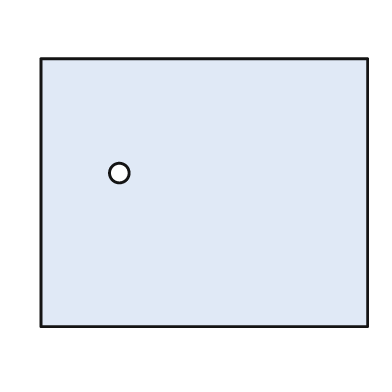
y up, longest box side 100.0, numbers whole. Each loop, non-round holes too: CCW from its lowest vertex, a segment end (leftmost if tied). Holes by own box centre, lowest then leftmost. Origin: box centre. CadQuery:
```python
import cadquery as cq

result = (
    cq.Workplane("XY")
    .moveTo(-50.0, -41.0)
    .lineTo(50.0, -41.0)
    .lineTo(50.0, 41.0)
    .lineTo(-50.0, 41.0)
    .close()
    .moveTo(-26.0, 6.0)
    .circle(3.0)
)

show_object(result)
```